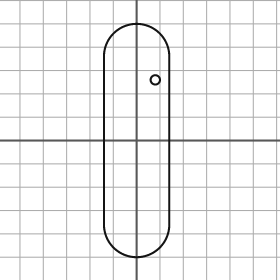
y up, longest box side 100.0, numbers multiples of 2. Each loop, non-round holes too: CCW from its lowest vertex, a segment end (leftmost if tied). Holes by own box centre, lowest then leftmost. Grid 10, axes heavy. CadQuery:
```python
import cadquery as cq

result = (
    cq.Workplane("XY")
    .moveTo(-14.0, -36.0)
    .threePointArc((0.0, -50.0), (14.0, -36.0))
    .lineTo(14.0, 36.0)
    .threePointArc((0.0, 50.0), (-14.0, 36.0))
    .close()
    .moveTo(8.0, 26.0)
    .circle(2.0)
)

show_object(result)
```